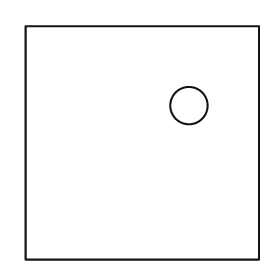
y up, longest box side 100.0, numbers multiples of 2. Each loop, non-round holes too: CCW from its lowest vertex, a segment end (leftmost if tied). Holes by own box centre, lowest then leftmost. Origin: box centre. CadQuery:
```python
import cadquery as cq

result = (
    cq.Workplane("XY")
    .moveTo(-50.0, -50.0)
    .lineTo(50.0, -50.0)
    .lineTo(50.0, 50.0)
    .lineTo(-50.0, 50.0)
    .close()
    .moveTo(20.0, 16.0)
    .circle(8.0)
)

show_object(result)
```